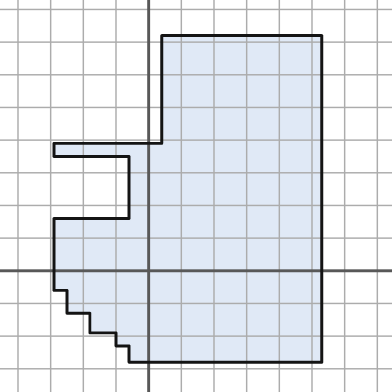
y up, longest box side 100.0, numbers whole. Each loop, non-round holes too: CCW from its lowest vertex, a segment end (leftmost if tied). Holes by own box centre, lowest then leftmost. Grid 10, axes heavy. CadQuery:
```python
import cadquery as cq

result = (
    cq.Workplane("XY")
    .moveTo(-6.0, -28.0)
    .lineTo(53.0, -28.0)
    .lineTo(53.0, 72.0)
    .lineTo(4.0, 72.0)
    .lineTo(4.0, 39.0)
    .lineTo(-29.0, 39.0)
    .lineTo(-29.0, 35.0)
    .lineTo(-6.0, 35.0)
    .lineTo(-6.0, 16.0)
    .lineTo(-29.0, 16.0)
    .lineTo(-29.0, -6.0)
    .lineTo(-25.0, -6.0)
    .lineTo(-25.0, -13.0)
    .lineTo(-18.0, -13.0)
    .lineTo(-18.0, -19.0)
    .lineTo(-10.0, -19.0)
    .lineTo(-10.0, -23.0)
    .lineTo(-6.0, -23.0)
    .close()
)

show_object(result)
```